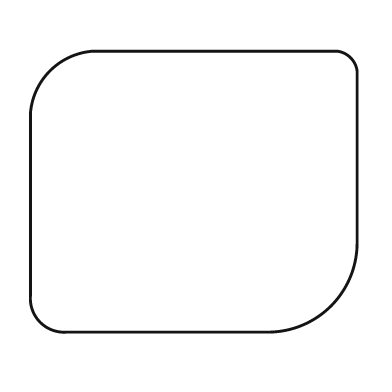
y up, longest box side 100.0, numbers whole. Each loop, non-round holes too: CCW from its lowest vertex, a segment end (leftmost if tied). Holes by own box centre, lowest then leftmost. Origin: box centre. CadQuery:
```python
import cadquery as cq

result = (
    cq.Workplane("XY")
    .moveTo(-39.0, -43.0)
    .lineTo(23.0, -43.0)
    .threePointArc((42.0, -35.0), (50.0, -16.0))
    .lineTo(50.0, 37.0)
    .threePointArc((48.0, 41.0), (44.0, 43.0))
    .lineTo(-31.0, 43.0)
    .threePointArc((-44.0, 37.0), (-50.0, 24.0))
    .lineTo(-50.0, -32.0)
    .threePointArc((-47.0, -40.0), (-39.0, -43.0))
    .close()
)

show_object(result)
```